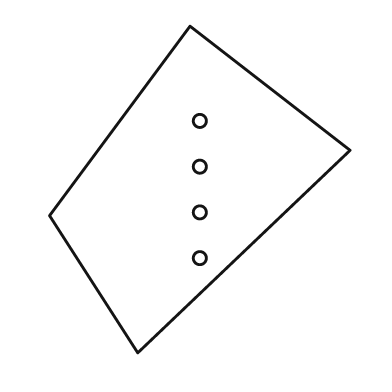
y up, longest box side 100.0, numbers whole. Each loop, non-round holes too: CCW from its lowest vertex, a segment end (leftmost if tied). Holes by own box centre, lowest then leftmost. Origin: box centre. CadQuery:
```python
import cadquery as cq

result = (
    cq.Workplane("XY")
    .moveTo(-19.0, -50.0)
    .lineTo(46.0, 12.0)
    .lineTo(-3.0, 50.0)
    .lineTo(-46.0, -8.0)
    .close()
    .moveTo(0.0, -21.0)
    .circle(2.0)
    .moveTo(0.0, -7.0)
    .circle(2.0)
    .moveTo(0.0, 7.0)
    .circle(2.0)
    .moveTo(0.0, 21.0)
    .circle(2.0)
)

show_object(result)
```